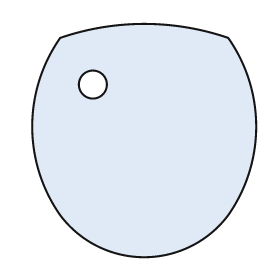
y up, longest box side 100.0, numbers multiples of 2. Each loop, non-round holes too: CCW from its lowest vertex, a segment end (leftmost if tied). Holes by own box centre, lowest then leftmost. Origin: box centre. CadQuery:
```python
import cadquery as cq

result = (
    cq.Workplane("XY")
    .moveTo(-36.0, -32.0)
    .threePointArc((0.0, -50.0), (36.0, -32.0))
    .threePointArc((48.0, 6.0), (36.0, 44.0))
    .threePointArc((0.0, 50.0), (-36.0, 44.0))
    .threePointArc((-48.0, 6.0), (-36.0, -32.0))
    .close()
    .moveTo(-22.0, 24.0)
    .circle(6.0)
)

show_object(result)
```